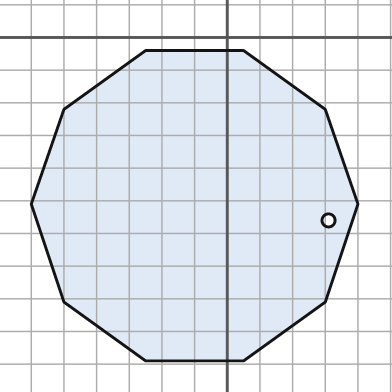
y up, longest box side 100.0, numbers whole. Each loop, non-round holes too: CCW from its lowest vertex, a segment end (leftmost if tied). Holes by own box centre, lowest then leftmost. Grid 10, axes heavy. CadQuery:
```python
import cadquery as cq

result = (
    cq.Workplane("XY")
    .moveTo(-25.0, -99.0)
    .lineTo(5.0, -99.0)
    .lineTo(30.0, -81.0)
    .lineTo(40.0, -51.0)
    .lineTo(30.0, -22.0)
    .lineTo(5.0, -4.0)
    .lineTo(-25.0, -4.0)
    .lineTo(-50.0, -22.0)
    .lineTo(-60.0, -51.0)
    .lineTo(-50.0, -81.0)
    .close()
    .moveTo(31.0, -56.0)
    .circle(2.0)
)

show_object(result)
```